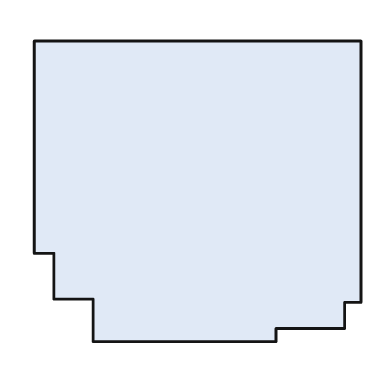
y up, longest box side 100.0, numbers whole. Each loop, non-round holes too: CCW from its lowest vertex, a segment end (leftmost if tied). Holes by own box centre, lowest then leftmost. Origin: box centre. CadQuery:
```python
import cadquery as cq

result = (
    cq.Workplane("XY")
    .moveTo(-32.0, -46.0)
    .lineTo(24.0, -46.0)
    .lineTo(24.0, -42.0)
    .lineTo(45.0, -42.0)
    .lineTo(45.0, -34.0)
    .lineTo(50.0, -34.0)
    .lineTo(50.0, 46.0)
    .lineTo(-50.0, 46.0)
    .lineTo(-50.0, -19.0)
    .lineTo(-44.0, -19.0)
    .lineTo(-44.0, -33.0)
    .lineTo(-32.0, -33.0)
    .close()
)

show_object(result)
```